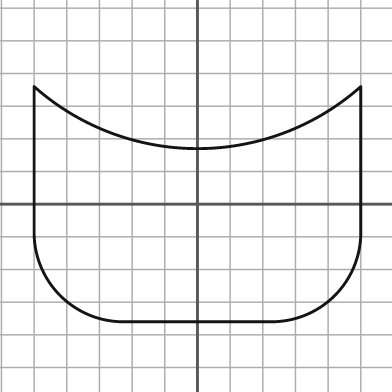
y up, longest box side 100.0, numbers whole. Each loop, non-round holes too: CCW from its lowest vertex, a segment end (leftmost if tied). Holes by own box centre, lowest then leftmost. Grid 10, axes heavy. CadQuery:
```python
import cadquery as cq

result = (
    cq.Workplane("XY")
    .moveTo(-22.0, -36.0)
    .lineTo(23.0, -36.0)
    .threePointArc((42.0, -28.0), (50.0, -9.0))
    .lineTo(50.0, 36.0)
    .threePointArc((0.0, 17.0), (-50.0, 36.0))
    .lineTo(-50.0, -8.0)
    .threePointArc((-42.0, -28.0), (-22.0, -36.0))
    .close()
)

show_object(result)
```